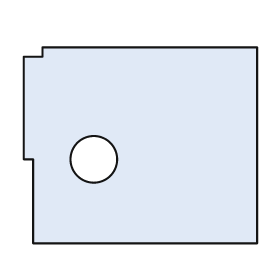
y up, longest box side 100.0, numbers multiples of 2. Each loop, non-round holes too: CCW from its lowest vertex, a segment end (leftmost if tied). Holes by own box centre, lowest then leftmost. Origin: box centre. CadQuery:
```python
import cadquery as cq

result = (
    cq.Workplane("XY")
    .moveTo(-46.0, -42.0)
    .lineTo(50.0, -42.0)
    .lineTo(50.0, 42.0)
    .lineTo(-42.0, 42.0)
    .lineTo(-42.0, 38.0)
    .lineTo(-50.0, 38.0)
    .lineTo(-50.0, -6.0)
    .lineTo(-46.0, -6.0)
    .close()
    .moveTo(-20.0, -6.0)
    .circle(10.0)
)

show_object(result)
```